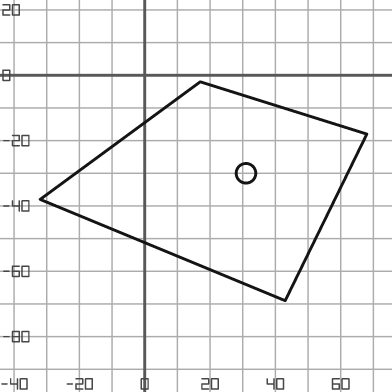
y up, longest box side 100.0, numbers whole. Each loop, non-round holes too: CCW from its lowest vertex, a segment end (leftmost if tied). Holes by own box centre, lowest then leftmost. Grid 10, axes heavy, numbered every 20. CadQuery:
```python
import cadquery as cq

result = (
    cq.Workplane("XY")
    .moveTo(43.0, -69.0)
    .lineTo(68.0, -18.0)
    .lineTo(17.0, -2.0)
    .lineTo(-32.0, -38.0)
    .close()
    .moveTo(31.0, -30.0)
    .circle(3.0)
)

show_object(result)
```